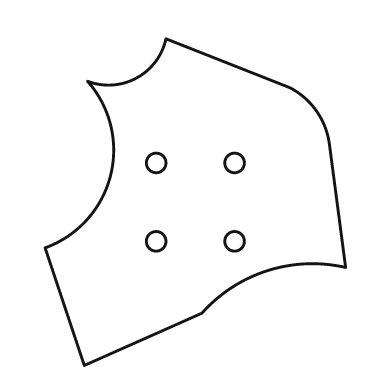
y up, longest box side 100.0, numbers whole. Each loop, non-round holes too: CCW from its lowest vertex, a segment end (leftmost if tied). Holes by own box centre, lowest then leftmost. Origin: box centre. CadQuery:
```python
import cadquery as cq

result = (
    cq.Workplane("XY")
    .moveTo(-34.0, -50.0)
    .lineTo(2.0, -34.0)
    .threePointArc((22.0, -21.0), (46.0, -20.0))
    .lineTo(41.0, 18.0)
    .threePointArc((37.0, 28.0), (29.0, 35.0))
    .lineTo(-9.0, 50.0)
    .threePointArc((-18.0, 38.0), (-33.0, 37.0))
    .threePointArc((-26.0, 8.0), (-46.0, -14.0))
    .close()
    .moveTo(-12.0, -12.0)
    .circle(3.0)
    .moveTo(12.0, -12.0)
    .circle(3.0)
    .moveTo(-12.0, 12.0)
    .circle(3.0)
    .moveTo(12.0, 12.0)
    .circle(3.0)
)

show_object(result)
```